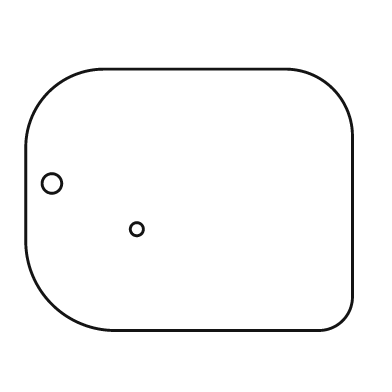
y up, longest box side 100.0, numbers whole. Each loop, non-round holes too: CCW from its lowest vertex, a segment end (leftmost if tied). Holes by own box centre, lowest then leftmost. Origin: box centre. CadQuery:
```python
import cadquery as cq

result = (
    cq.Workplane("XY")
    .moveTo(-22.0, -40.0)
    .lineTo(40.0, -40.0)
    .threePointArc((47.0, -37.0), (50.0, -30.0))
    .lineTo(50.0, 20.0)
    .threePointArc((44.0, 34.0), (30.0, 40.0))
    .lineTo(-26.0, 40.0)
    .threePointArc((-43.0, 33.0), (-50.0, 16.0))
    .lineTo(-50.0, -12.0)
    .threePointArc((-42.0, -32.0), (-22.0, -40.0))
    .close()
    .moveTo(-16.0, -9.0)
    .circle(2.0)
    .moveTo(-42.0, 5.0)
    .circle(3.0)
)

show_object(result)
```